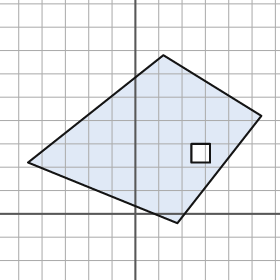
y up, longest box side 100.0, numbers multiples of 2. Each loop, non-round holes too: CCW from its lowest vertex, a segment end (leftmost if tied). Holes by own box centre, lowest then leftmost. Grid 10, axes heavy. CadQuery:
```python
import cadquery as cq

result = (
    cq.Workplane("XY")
    .moveTo(18.0, -4.0)
    .lineTo(54.0, 42.0)
    .lineTo(12.0, 68.0)
    .lineTo(-46.0, 22.0)
    .close()
    .moveTo(24.0, 22.0)
    .lineTo(32.0, 22.0)
    .lineTo(32.0, 30.0)
    .lineTo(24.0, 30.0)
    .close()
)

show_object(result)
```